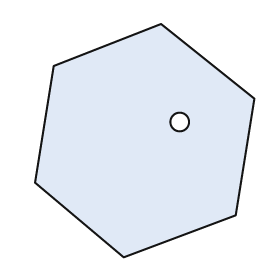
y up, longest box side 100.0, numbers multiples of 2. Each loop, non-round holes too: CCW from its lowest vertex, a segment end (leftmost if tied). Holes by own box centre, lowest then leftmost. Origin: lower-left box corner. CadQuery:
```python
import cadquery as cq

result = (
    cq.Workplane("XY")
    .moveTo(38.0, 0.0)
    .lineTo(86.0, 18.0)
    .lineTo(94.0, 68.0)
    .lineTo(54.0, 100.0)
    .lineTo(8.0, 82.0)
    .lineTo(0.0, 32.0)
    .close()
    .moveTo(62.0, 58.0)
    .circle(4.0)
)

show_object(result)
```